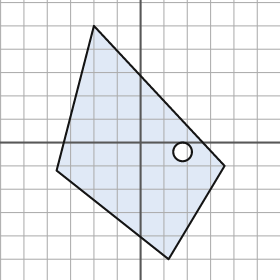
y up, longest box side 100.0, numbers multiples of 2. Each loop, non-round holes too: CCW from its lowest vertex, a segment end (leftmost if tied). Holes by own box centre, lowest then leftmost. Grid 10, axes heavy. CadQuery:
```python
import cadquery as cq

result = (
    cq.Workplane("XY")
    .moveTo(12.0, -50.0)
    .lineTo(36.0, -10.0)
    .lineTo(-20.0, 50.0)
    .lineTo(-36.0, -12.0)
    .close()
    .moveTo(18.0, -4.0)
    .circle(4.0)
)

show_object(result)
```